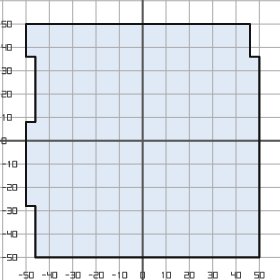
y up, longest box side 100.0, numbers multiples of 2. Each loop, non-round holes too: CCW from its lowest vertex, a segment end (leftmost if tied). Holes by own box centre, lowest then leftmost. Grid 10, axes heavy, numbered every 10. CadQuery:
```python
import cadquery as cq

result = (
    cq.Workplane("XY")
    .moveTo(-46.0, -50.0)
    .lineTo(50.0, -50.0)
    .lineTo(50.0, 36.0)
    .lineTo(46.0, 36.0)
    .lineTo(46.0, 50.0)
    .lineTo(-50.0, 50.0)
    .lineTo(-50.0, 36.0)
    .lineTo(-46.0, 36.0)
    .lineTo(-46.0, 8.0)
    .lineTo(-50.0, 8.0)
    .lineTo(-50.0, -28.0)
    .lineTo(-46.0, -28.0)
    .close()
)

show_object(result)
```